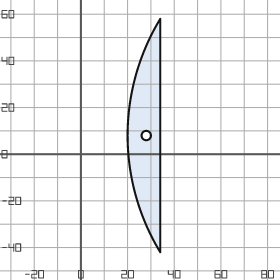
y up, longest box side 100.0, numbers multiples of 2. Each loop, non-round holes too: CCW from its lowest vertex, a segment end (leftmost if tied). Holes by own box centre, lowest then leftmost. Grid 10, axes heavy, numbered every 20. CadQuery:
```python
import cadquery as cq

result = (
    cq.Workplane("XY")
    .moveTo(34.0, -42.0)
    .lineTo(34.0, 58.0)
    .threePointArc((20.0, 8.0), (34.0, -42.0))
    .close()
    .moveTo(28.0, 8.0)
    .circle(2.0)
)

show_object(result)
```